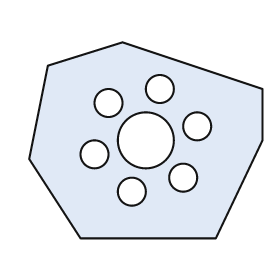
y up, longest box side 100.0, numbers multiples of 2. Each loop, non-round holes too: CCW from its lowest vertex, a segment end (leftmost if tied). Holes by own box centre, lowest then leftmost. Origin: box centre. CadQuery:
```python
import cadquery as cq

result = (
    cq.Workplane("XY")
    .moveTo(-28.0, -42.0)
    .lineTo(30.0, -42.0)
    .lineTo(50.0, 0.0)
    .lineTo(50.0, 22.0)
    .lineTo(-10.0, 42.0)
    .lineTo(-42.0, 32.0)
    .lineTo(-50.0, -8.0)
    .close()
    .moveTo(-6.0, -22.0)
    .circle(6.0)
    .moveTo(16.0, -16.0)
    .circle(6.0)
    .moveTo(-22.0, -6.0)
    .circle(6.0)
    .moveTo(0.0, 0.0)
    .circle(12.0)
    .moveTo(22.0, 6.0)
    .circle(6.0)
    .moveTo(-16.0, 16.0)
    .circle(6.0)
    .moveTo(6.0, 22.0)
    .circle(6.0)
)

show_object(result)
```